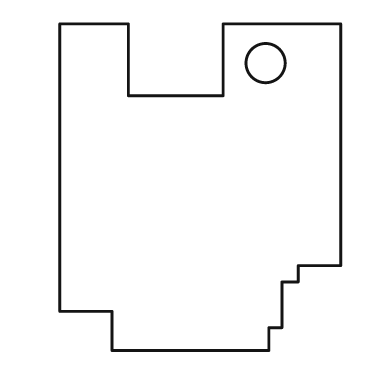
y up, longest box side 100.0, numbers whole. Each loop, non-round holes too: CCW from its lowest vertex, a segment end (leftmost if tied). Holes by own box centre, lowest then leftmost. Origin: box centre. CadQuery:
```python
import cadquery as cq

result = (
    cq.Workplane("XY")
    .moveTo(-27.0, -50.0)
    .lineTo(21.0, -50.0)
    .lineTo(21.0, -43.0)
    .lineTo(25.0, -43.0)
    .lineTo(25.0, -29.0)
    .lineTo(30.0, -29.0)
    .lineTo(30.0, -24.0)
    .lineTo(43.0, -24.0)
    .lineTo(43.0, 50.0)
    .lineTo(7.0, 50.0)
    .lineTo(7.0, 28.0)
    .lineTo(-22.0, 28.0)
    .lineTo(-22.0, 50.0)
    .lineTo(-43.0, 50.0)
    .lineTo(-43.0, -38.0)
    .lineTo(-27.0, -38.0)
    .close()
    .moveTo(20.0, 38.0)
    .circle(6.0)
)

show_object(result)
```